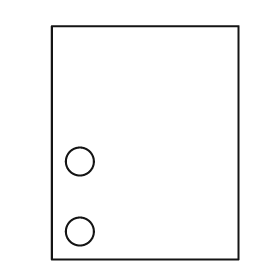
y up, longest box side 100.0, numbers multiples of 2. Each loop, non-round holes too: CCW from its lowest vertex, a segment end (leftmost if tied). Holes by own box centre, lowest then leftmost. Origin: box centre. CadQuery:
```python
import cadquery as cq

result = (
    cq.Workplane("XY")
    .moveTo(-40.0, -50.0)
    .lineTo(40.0, -50.0)
    .lineTo(40.0, 50.0)
    .lineTo(-40.0, 50.0)
    .close()
    .moveTo(-28.0, -38.0)
    .circle(6.0)
    .moveTo(-28.0, -8.0)
    .circle(6.0)
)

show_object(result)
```